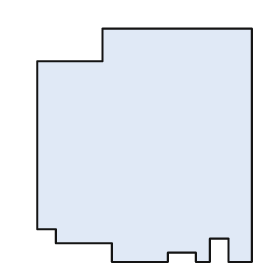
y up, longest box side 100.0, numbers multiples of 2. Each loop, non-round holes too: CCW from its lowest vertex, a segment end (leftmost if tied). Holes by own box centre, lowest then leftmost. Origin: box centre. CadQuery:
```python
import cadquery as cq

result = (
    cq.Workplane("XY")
    .moveTo(-14.0, -50.0)
    .lineTo(10.0, -50.0)
    .lineTo(10.0, -46.0)
    .lineTo(22.0, -46.0)
    .lineTo(22.0, -50.0)
    .lineTo(28.0, -50.0)
    .lineTo(28.0, -40.0)
    .lineTo(36.0, -40.0)
    .lineTo(36.0, -50.0)
    .lineTo(46.0, -50.0)
    .lineTo(46.0, 50.0)
    .lineTo(-18.0, 50.0)
    .lineTo(-18.0, 36.0)
    .lineTo(-46.0, 36.0)
    .lineTo(-46.0, -36.0)
    .lineTo(-38.0, -36.0)
    .lineTo(-38.0, -42.0)
    .lineTo(-14.0, -42.0)
    .close()
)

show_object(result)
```